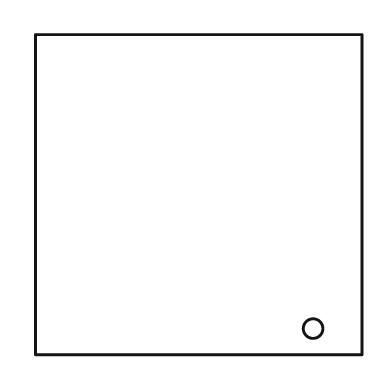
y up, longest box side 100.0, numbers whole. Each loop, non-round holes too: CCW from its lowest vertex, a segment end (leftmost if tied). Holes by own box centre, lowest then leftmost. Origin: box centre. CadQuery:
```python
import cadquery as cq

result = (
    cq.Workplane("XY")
    .moveTo(-50.0, -49.0)
    .lineTo(50.0, -49.0)
    .lineTo(50.0, 49.0)
    .lineTo(-50.0, 49.0)
    .close()
    .moveTo(35.0, -41.0)
    .circle(3.0)
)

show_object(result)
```